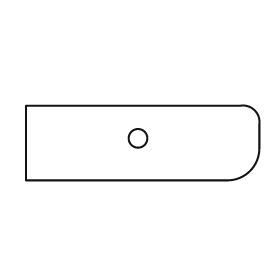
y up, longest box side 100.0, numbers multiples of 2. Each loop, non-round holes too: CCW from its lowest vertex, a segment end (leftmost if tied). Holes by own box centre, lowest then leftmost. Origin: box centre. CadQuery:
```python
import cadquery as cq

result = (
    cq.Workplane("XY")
    .moveTo(-50.0, -16.0)
    .lineTo(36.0, -16.0)
    .threePointArc((46.0, -12.0), (50.0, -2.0))
    .lineTo(50.0, 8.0)
    .threePointArc((48.0, 14.0), (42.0, 16.0))
    .lineTo(-50.0, 16.0)
    .close()
    .moveTo(-2.0, 2.0)
    .circle(4.0)
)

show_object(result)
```